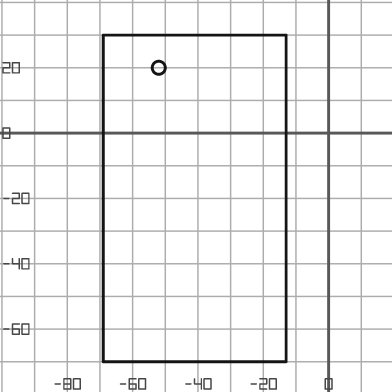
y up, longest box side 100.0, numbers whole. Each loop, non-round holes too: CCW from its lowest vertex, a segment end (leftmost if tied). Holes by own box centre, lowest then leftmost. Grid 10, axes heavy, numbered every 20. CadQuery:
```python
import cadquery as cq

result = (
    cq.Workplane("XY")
    .moveTo(-69.0, -70.0)
    .lineTo(-13.0, -70.0)
    .lineTo(-13.0, 30.0)
    .lineTo(-69.0, 30.0)
    .close()
    .moveTo(-52.0, 20.0)
    .circle(2.0)
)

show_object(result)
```